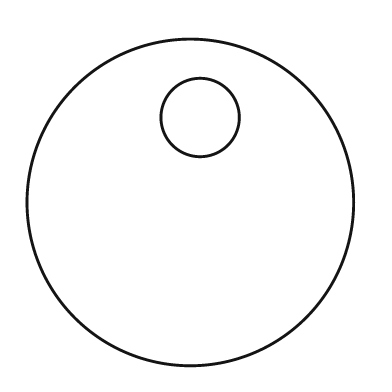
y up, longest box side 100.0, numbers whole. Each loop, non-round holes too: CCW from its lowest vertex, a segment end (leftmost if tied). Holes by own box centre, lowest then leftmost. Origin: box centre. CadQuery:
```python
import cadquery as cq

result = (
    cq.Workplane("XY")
    .moveTo(0.0, 0.0)
    .circle(50.0)
    .moveTo(3.0, 26.0)
    .circle(12.0)
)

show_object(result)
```